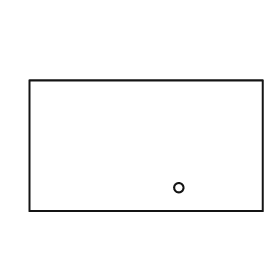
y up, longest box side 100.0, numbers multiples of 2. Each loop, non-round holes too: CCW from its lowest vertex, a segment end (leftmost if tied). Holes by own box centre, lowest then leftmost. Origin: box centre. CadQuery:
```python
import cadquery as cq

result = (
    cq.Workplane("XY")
    .moveTo(-50.0, -28.0)
    .lineTo(50.0, -28.0)
    .lineTo(50.0, 28.0)
    .lineTo(-50.0, 28.0)
    .close()
    .moveTo(14.0, -18.0)
    .circle(2.0)
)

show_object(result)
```